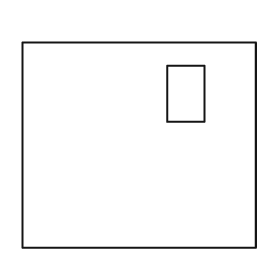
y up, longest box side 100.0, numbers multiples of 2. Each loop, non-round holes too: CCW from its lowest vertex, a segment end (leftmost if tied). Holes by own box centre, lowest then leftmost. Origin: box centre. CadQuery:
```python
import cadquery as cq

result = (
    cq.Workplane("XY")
    .moveTo(-50.0, -44.0)
    .lineTo(50.0, -44.0)
    .lineTo(50.0, 44.0)
    .lineTo(-50.0, 44.0)
    .close()
    .moveTo(12.0, 10.0)
    .lineTo(28.0, 10.0)
    .lineTo(28.0, 34.0)
    .lineTo(12.0, 34.0)
    .close()
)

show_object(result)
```